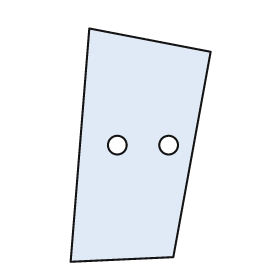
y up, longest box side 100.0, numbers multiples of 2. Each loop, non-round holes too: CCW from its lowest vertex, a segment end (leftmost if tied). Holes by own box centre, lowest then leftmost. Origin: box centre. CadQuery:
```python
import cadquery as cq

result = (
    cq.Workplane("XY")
    .moveTo(-30.0, -50.0)
    .lineTo(14.0, -48.0)
    .lineTo(30.0, 40.0)
    .lineTo(-22.0, 50.0)
    .close()
    .moveTo(-10.0, 0.0)
    .circle(4.0)
    .moveTo(12.0, 0.0)
    .circle(4.0)
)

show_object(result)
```